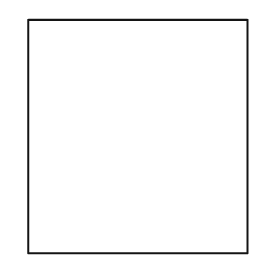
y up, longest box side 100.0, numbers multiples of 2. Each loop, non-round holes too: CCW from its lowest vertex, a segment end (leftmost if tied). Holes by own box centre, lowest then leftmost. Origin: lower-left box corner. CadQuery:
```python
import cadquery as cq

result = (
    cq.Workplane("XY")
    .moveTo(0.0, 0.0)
    .lineTo(94.0, 0.0)
    .lineTo(94.0, 100.0)
    .lineTo(0.0, 100.0)
    .close()
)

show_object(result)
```